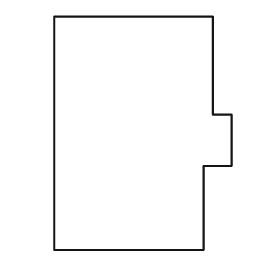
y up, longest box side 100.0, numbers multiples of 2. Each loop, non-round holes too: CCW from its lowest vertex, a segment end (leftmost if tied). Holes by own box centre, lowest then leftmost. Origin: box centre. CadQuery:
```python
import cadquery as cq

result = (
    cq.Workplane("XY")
    .moveTo(-38.0, -50.0)
    .lineTo(26.0, -50.0)
    .lineTo(26.0, -14.0)
    .lineTo(38.0, -14.0)
    .lineTo(38.0, 8.0)
    .lineTo(30.0, 8.0)
    .lineTo(30.0, 50.0)
    .lineTo(-38.0, 50.0)
    .close()
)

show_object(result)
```